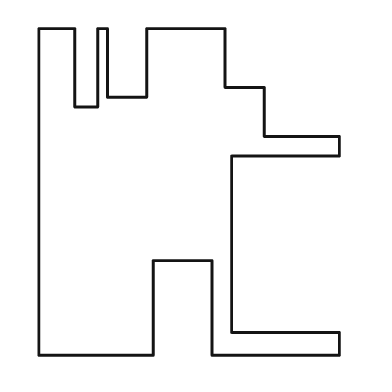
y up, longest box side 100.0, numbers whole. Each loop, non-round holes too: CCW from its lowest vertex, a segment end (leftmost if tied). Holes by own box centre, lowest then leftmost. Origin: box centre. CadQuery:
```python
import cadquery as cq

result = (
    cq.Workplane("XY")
    .moveTo(-46.0, -50.0)
    .lineTo(-11.0, -50.0)
    .lineTo(-11.0, -21.0)
    .lineTo(7.0, -21.0)
    .lineTo(7.0, -50.0)
    .lineTo(46.0, -50.0)
    .lineTo(46.0, -43.0)
    .lineTo(13.0, -43.0)
    .lineTo(13.0, 11.0)
    .lineTo(46.0, 11.0)
    .lineTo(46.0, 17.0)
    .lineTo(23.0, 17.0)
    .lineTo(23.0, 32.0)
    .lineTo(11.0, 32.0)
    .lineTo(11.0, 50.0)
    .lineTo(-13.0, 50.0)
    .lineTo(-13.0, 29.0)
    .lineTo(-25.0, 29.0)
    .lineTo(-25.0, 50.0)
    .lineTo(-28.0, 50.0)
    .lineTo(-28.0, 26.0)
    .lineTo(-35.0, 26.0)
    .lineTo(-35.0, 50.0)
    .lineTo(-46.0, 50.0)
    .close()
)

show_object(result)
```